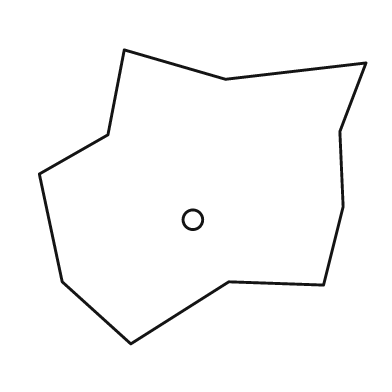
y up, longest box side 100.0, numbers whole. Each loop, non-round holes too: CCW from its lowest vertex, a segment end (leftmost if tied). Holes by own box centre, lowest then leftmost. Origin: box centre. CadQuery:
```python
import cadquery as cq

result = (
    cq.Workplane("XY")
    .moveTo(-22.0, -45.0)
    .lineTo(8.0, -26.0)
    .lineTo(37.0, -27.0)
    .lineTo(43.0, -3.0)
    .lineTo(42.0, 20.0)
    .lineTo(50.0, 41.0)
    .lineTo(7.0, 36.0)
    .lineTo(-24.0, 45.0)
    .lineTo(-29.0, 19.0)
    .lineTo(-50.0, 7.0)
    .lineTo(-43.0, -26.0)
    .close()
    .moveTo(-3.0, -7.0)
    .circle(3.0)
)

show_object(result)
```